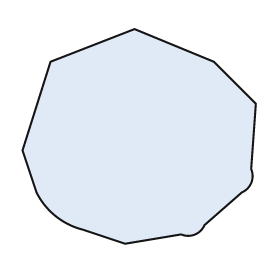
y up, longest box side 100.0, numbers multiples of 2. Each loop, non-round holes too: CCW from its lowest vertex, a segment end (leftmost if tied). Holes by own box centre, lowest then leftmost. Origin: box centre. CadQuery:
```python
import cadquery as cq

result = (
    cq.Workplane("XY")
    .moveTo(-6.0, -46.0)
    .lineTo(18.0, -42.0)
    .threePointArc((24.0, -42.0), (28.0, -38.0))
    .lineTo(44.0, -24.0)
    .threePointArc((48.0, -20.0), (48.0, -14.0))
    .lineTo(50.0, 14.0)
    .lineTo(32.0, 32.0)
    .lineTo(-2.0, 46.0)
    .lineTo(-38.0, 32.0)
    .lineTo(-50.0, -6.0)
    .lineTo(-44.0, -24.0)
    .threePointArc((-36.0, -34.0), (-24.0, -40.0))
    .close()
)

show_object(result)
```